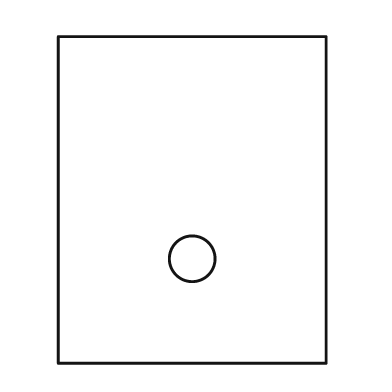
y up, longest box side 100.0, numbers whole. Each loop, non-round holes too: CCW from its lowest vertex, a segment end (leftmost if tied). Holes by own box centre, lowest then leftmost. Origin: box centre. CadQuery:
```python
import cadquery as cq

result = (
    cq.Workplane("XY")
    .moveTo(-41.0, -50.0)
    .lineTo(41.0, -50.0)
    .lineTo(41.0, 50.0)
    .lineTo(-41.0, 50.0)
    .close()
    .moveTo(0.0, -18.0)
    .circle(7.0)
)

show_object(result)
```